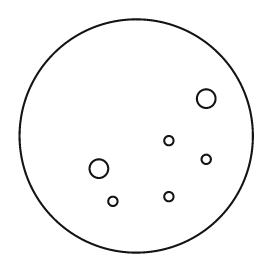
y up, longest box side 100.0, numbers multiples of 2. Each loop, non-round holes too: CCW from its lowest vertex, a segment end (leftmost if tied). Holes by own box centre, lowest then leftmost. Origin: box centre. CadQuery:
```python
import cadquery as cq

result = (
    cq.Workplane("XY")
    .moveTo(0.0, 0.0)
    .circle(50.0)
    .moveTo(-10.0, -28.0)
    .circle(2.0)
    .moveTo(14.0, -26.0)
    .circle(2.0)
    .moveTo(-16.0, -14.0)
    .circle(4.0)
    .moveTo(30.0, -10.0)
    .circle(2.0)
    .moveTo(14.0, -2.0)
    .circle(2.0)
    .moveTo(30.0, 16.0)
    .circle(4.0)
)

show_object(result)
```